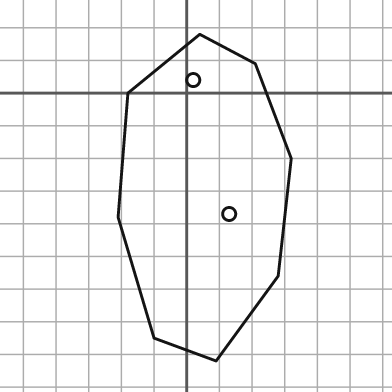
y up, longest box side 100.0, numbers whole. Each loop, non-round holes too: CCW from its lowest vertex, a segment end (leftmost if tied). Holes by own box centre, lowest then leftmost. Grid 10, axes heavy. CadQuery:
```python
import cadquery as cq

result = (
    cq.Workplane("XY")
    .moveTo(9.0, -82.0)
    .lineTo(28.0, -56.0)
    .lineTo(32.0, -20.0)
    .lineTo(21.0, 9.0)
    .lineTo(4.0, 18.0)
    .lineTo(-18.0, 0.0)
    .lineTo(-21.0, -38.0)
    .lineTo(-10.0, -75.0)
    .close()
    .moveTo(13.0, -37.0)
    .circle(2.0)
    .moveTo(2.0, 4.0)
    .circle(2.0)
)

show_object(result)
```